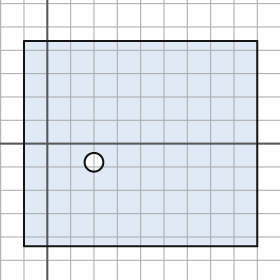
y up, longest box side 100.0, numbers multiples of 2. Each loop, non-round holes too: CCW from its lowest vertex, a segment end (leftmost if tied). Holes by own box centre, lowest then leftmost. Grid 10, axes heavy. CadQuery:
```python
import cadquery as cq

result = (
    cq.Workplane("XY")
    .moveTo(-10.0, -44.0)
    .lineTo(90.0, -44.0)
    .lineTo(90.0, 44.0)
    .lineTo(-10.0, 44.0)
    .close()
    .moveTo(20.0, -8.0)
    .circle(4.0)
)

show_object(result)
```